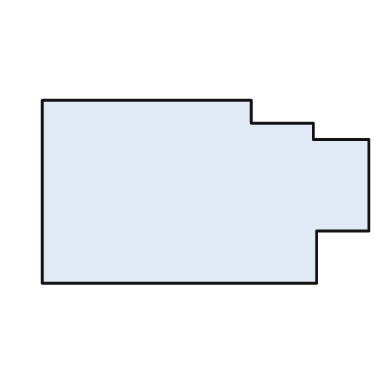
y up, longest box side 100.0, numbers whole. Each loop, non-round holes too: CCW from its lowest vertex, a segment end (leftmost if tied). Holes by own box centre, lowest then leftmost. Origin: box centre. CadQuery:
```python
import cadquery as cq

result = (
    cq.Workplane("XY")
    .moveTo(-50.0, -28.0)
    .lineTo(34.0, -28.0)
    .lineTo(34.0, -12.0)
    .lineTo(50.0, -12.0)
    .lineTo(50.0, 16.0)
    .lineTo(33.0, 16.0)
    .lineTo(33.0, 21.0)
    .lineTo(14.0, 21.0)
    .lineTo(14.0, 28.0)
    .lineTo(-50.0, 28.0)
    .close()
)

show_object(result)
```